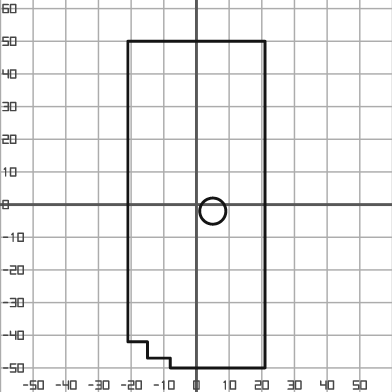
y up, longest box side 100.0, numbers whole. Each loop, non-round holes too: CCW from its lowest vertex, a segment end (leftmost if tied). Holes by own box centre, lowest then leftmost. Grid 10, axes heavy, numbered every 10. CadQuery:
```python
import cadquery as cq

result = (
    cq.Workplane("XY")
    .moveTo(-8.0, -50.0)
    .lineTo(21.0, -50.0)
    .lineTo(21.0, 50.0)
    .lineTo(-21.0, 50.0)
    .lineTo(-21.0, -42.0)
    .lineTo(-15.0, -42.0)
    .lineTo(-15.0, -47.0)
    .lineTo(-8.0, -47.0)
    .close()
    .moveTo(5.0, -2.0)
    .circle(4.0)
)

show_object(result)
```